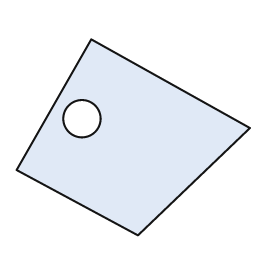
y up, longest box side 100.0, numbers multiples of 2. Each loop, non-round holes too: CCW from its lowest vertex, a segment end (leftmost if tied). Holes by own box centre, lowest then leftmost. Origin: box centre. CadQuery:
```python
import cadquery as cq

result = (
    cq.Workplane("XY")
    .moveTo(2.0, -42.0)
    .lineTo(50.0, 4.0)
    .lineTo(-18.0, 42.0)
    .lineTo(-50.0, -14.0)
    .close()
    .moveTo(-22.0, 8.0)
    .circle(8.0)
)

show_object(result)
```